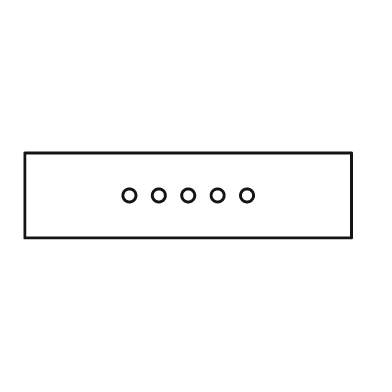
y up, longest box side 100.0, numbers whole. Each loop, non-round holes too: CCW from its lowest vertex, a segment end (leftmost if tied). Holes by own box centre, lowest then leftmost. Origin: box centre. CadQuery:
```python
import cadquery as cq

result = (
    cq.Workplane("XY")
    .moveTo(-50.0, -13.0)
    .lineTo(50.0, -13.0)
    .lineTo(50.0, 13.0)
    .lineTo(-50.0, 13.0)
    .close()
    .moveTo(-18.0, 0.0)
    .circle(2.0)
    .moveTo(-9.0, 0.0)
    .circle(2.0)
    .moveTo(0.0, 0.0)
    .circle(2.0)
    .moveTo(9.0, 0.0)
    .circle(2.0)
    .moveTo(18.0, 0.0)
    .circle(2.0)
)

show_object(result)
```